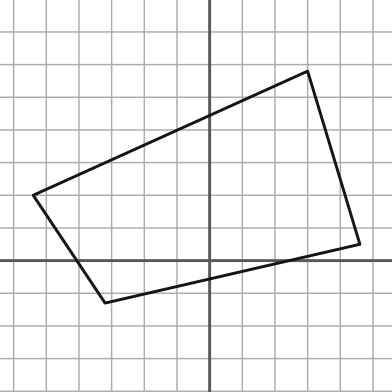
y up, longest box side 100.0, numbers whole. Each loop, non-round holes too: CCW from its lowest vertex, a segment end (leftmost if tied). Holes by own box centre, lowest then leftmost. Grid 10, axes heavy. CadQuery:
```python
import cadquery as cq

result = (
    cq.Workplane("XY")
    .moveTo(-32.0, -13.0)
    .lineTo(46.0, 5.0)
    .lineTo(30.0, 58.0)
    .lineTo(-54.0, 20.0)
    .close()
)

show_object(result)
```